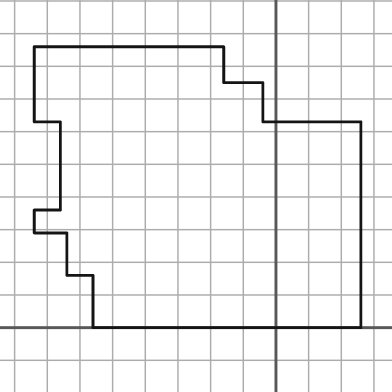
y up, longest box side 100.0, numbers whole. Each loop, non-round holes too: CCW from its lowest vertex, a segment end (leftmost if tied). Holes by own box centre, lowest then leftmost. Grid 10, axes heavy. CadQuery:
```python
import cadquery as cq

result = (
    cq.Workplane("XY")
    .moveTo(-56.0, 0.0)
    .lineTo(26.0, 0.0)
    .lineTo(26.0, 63.0)
    .lineTo(-4.0, 63.0)
    .lineTo(-4.0, 75.0)
    .lineTo(-16.0, 75.0)
    .lineTo(-16.0, 86.0)
    .lineTo(-74.0, 86.0)
    .lineTo(-74.0, 63.0)
    .lineTo(-66.0, 63.0)
    .lineTo(-66.0, 36.0)
    .lineTo(-74.0, 36.0)
    .lineTo(-74.0, 29.0)
    .lineTo(-64.0, 29.0)
    .lineTo(-64.0, 16.0)
    .lineTo(-56.0, 16.0)
    .close()
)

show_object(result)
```